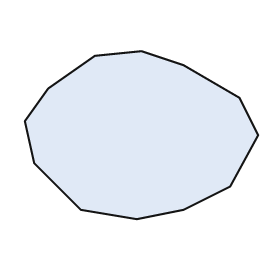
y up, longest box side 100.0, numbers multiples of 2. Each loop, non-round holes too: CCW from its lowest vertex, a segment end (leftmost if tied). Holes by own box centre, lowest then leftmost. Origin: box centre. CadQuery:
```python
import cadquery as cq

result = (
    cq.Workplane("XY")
    .moveTo(-2.0, -36.0)
    .lineTo(18.0, -32.0)
    .lineTo(38.0, -22.0)
    .lineTo(50.0, 0.0)
    .lineTo(42.0, 16.0)
    .lineTo(18.0, 30.0)
    .lineTo(0.0, 36.0)
    .lineTo(-20.0, 34.0)
    .lineTo(-40.0, 20.0)
    .lineTo(-50.0, 6.0)
    .lineTo(-46.0, -12.0)
    .lineTo(-26.0, -32.0)
    .close()
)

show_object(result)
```